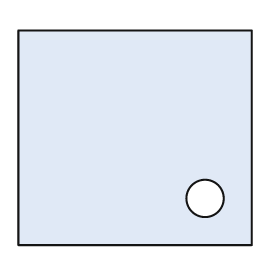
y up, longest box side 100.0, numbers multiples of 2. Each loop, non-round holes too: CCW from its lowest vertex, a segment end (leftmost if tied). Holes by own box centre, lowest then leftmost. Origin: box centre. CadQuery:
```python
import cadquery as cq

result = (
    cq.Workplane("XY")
    .moveTo(-50.0, -46.0)
    .lineTo(50.0, -46.0)
    .lineTo(50.0, 46.0)
    .lineTo(-50.0, 46.0)
    .close()
    .moveTo(30.0, -26.0)
    .circle(8.0)
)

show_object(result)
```